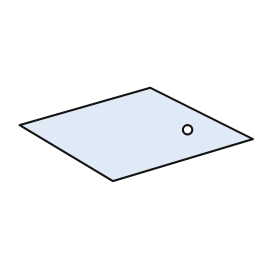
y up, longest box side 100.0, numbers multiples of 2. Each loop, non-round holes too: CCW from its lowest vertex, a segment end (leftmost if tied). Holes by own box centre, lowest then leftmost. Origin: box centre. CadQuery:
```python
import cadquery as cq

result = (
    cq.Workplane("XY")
    .moveTo(-10.0, -20.0)
    .lineTo(50.0, -2.0)
    .lineTo(6.0, 20.0)
    .lineTo(-50.0, 4.0)
    .close()
    .moveTo(22.0, 2.0)
    .circle(2.0)
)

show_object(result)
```